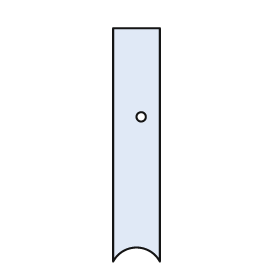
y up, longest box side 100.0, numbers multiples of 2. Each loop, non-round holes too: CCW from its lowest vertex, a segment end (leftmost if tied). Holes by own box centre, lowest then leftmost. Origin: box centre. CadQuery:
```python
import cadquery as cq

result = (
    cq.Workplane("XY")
    .moveTo(-10.0, -50.0)
    .threePointArc((0.0, -44.0), (10.0, -50.0))
    .lineTo(10.0, 50.0)
    .lineTo(-10.0, 50.0)
    .close()
    .moveTo(2.0, 12.0)
    .circle(2.0)
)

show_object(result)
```